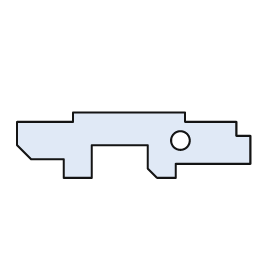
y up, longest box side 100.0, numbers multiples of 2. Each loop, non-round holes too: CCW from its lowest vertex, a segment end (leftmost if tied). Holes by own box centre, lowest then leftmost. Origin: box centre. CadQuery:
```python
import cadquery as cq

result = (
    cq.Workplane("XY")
    .moveTo(-30.0, -14.0)
    .lineTo(-18.0, -14.0)
    .lineTo(-18.0, 0.0)
    .lineTo(6.0, 0.0)
    .lineTo(6.0, -10.0)
    .lineTo(10.0, -14.0)
    .lineTo(18.0, -14.0)
    .lineTo(18.0, -8.0)
    .lineTo(50.0, -8.0)
    .lineTo(50.0, 4.0)
    .lineTo(44.0, 4.0)
    .lineTo(44.0, 10.0)
    .lineTo(22.0, 10.0)
    .lineTo(22.0, 14.0)
    .lineTo(-26.0, 14.0)
    .lineTo(-26.0, 10.0)
    .lineTo(-50.0, 10.0)
    .lineTo(-50.0, 0.0)
    .lineTo(-44.0, -6.0)
    .lineTo(-30.0, -6.0)
    .close()
    .moveTo(20.0, 2.0)
    .circle(4.0)
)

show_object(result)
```